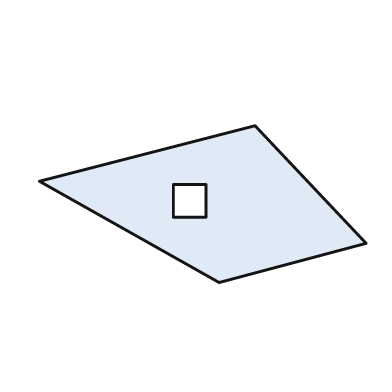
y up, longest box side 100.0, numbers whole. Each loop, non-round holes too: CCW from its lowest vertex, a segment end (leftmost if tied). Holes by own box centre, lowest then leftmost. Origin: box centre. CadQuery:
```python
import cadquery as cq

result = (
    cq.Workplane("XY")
    .moveTo(5.0, -24.0)
    .lineTo(50.0, -12.0)
    .lineTo(16.0, 24.0)
    .lineTo(-50.0, 7.0)
    .close()
    .moveTo(-9.0, -4.0)
    .lineTo(1.0, -4.0)
    .lineTo(1.0, 6.0)
    .lineTo(-9.0, 6.0)
    .close()
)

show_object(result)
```